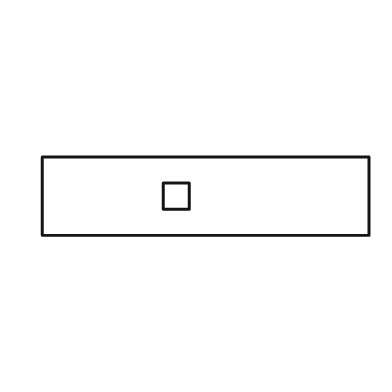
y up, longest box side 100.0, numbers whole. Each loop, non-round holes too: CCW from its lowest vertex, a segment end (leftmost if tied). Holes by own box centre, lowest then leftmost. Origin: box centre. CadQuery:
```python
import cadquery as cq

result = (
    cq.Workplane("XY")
    .moveTo(-50.0, -12.0)
    .lineTo(50.0, -12.0)
    .lineTo(50.0, 12.0)
    .lineTo(-50.0, 12.0)
    .close()
    .moveTo(-13.0, -4.0)
    .lineTo(-5.0, -4.0)
    .lineTo(-5.0, 4.0)
    .lineTo(-13.0, 4.0)
    .close()
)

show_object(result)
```